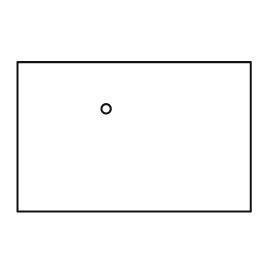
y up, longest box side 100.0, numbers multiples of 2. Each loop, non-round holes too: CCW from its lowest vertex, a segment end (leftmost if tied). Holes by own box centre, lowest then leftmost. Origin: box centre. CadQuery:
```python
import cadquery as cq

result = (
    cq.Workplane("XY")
    .moveTo(-50.0, -32.0)
    .lineTo(50.0, -32.0)
    .lineTo(50.0, 32.0)
    .lineTo(-50.0, 32.0)
    .close()
    .moveTo(-12.0, 12.0)
    .circle(2.0)
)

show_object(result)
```